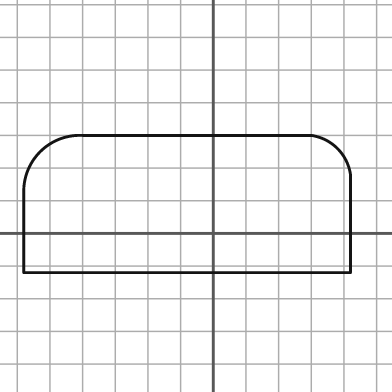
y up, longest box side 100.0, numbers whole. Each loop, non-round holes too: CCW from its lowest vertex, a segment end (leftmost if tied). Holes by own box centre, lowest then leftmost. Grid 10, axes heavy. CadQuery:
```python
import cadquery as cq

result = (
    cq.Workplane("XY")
    .moveTo(-58.0, -12.0)
    .lineTo(42.0, -12.0)
    .lineTo(42.0, 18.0)
    .threePointArc((38.0, 26.0), (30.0, 30.0))
    .lineTo(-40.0, 30.0)
    .threePointArc((-53.0, 25.0), (-58.0, 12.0))
    .close()
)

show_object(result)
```